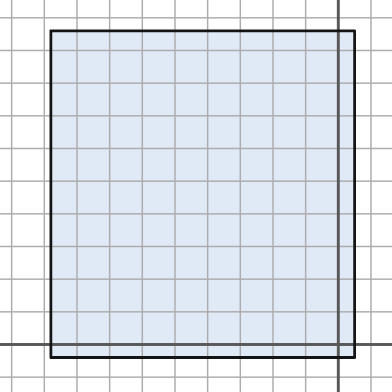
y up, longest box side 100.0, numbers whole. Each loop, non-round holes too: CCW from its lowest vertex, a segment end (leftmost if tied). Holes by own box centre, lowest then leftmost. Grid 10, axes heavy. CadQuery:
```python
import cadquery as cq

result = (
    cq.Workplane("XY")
    .moveTo(-88.0, -4.0)
    .lineTo(5.0, -4.0)
    .lineTo(5.0, 96.0)
    .lineTo(-88.0, 96.0)
    .close()
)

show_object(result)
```